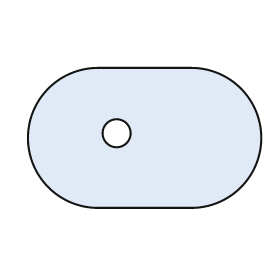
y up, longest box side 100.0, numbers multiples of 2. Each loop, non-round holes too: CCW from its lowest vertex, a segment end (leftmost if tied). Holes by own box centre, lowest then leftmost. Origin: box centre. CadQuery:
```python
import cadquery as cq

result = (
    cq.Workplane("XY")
    .moveTo(-20.0, -30.0)
    .lineTo(20.0, -30.0)
    .threePointArc((50.0, 0.0), (20.0, 30.0))
    .lineTo(-20.0, 30.0)
    .threePointArc((-50.0, 0.0), (-20.0, -30.0))
    .close()
    .moveTo(-12.0, 2.0)
    .circle(6.0)
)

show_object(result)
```